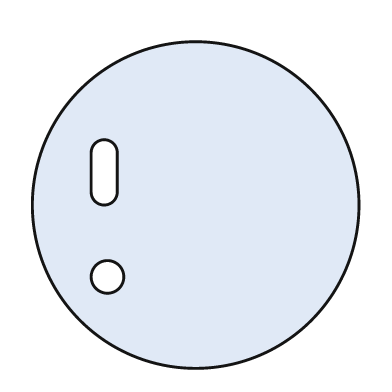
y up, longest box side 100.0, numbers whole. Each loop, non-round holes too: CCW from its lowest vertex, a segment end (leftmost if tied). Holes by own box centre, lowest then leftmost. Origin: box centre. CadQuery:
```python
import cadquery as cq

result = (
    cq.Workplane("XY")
    .moveTo(0.0, 0.0)
    .circle(50.0)
    .moveTo(-27.0, -22.0)
    .circle(5.0)
    .moveTo(-32.0, 4.0)
    .threePointArc((-28.0, 0.0), (-24.0, 4.0))
    .lineTo(-24.0, 16.0)
    .threePointArc((-28.0, 20.0), (-32.0, 16.0))
    .close()
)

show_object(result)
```